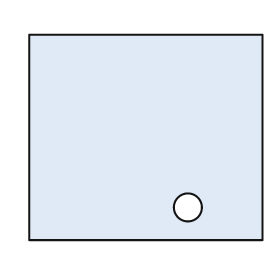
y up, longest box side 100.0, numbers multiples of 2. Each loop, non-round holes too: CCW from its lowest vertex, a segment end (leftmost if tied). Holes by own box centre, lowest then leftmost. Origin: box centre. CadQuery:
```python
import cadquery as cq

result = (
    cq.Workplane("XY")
    .moveTo(-50.0, -44.0)
    .lineTo(50.0, -44.0)
    .lineTo(50.0, 44.0)
    .lineTo(-50.0, 44.0)
    .close()
    .moveTo(18.0, -30.0)
    .circle(6.0)
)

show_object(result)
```